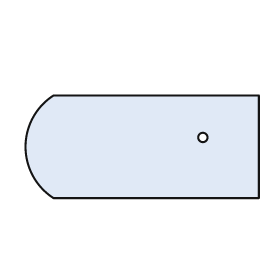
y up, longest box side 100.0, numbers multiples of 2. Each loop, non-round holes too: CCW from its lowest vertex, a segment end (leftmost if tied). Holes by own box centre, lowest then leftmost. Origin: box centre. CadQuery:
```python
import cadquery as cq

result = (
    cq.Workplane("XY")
    .moveTo(-38.0, -22.0)
    .lineTo(50.0, -22.0)
    .lineTo(50.0, 22.0)
    .lineTo(-38.0, 22.0)
    .threePointArc((-50.0, 0.0), (-38.0, -22.0))
    .close()
    .moveTo(26.0, 4.0)
    .circle(2.0)
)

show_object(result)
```